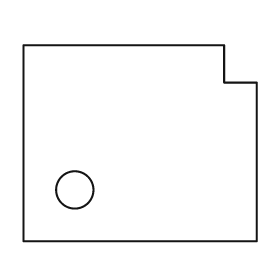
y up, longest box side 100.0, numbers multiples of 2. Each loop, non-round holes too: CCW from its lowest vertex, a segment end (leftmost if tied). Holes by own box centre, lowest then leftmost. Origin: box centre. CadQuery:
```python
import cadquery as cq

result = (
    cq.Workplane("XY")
    .moveTo(-50.0, -42.0)
    .lineTo(50.0, -42.0)
    .lineTo(50.0, 26.0)
    .lineTo(36.0, 26.0)
    .lineTo(36.0, 42.0)
    .lineTo(-50.0, 42.0)
    .close()
    .moveTo(-28.0, -20.0)
    .circle(8.0)
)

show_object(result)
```